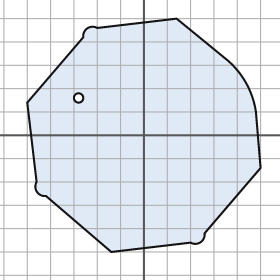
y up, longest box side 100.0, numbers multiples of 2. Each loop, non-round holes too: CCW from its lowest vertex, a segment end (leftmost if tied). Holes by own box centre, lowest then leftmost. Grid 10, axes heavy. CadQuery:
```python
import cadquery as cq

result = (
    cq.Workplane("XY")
    .moveTo(-14.0, -50.0)
    .lineTo(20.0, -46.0)
    .threePointArc((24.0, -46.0), (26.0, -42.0))
    .lineTo(50.0, -14.0)
    .lineTo(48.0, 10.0)
    .threePointArc((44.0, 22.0), (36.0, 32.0))
    .lineTo(14.0, 50.0)
    .lineTo(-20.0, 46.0)
    .threePointArc((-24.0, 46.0), (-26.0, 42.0))
    .lineTo(-50.0, 14.0)
    .lineTo(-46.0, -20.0)
    .threePointArc((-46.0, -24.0), (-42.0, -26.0))
    .close()
    .moveTo(-28.0, 16.0)
    .circle(2.0)
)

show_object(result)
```